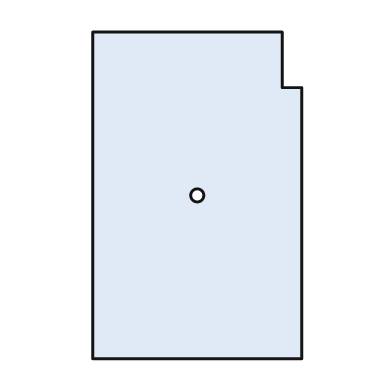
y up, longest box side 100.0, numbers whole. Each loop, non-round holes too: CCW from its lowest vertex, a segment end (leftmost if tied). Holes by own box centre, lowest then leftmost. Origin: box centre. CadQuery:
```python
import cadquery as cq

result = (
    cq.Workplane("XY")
    .moveTo(-32.0, -50.0)
    .lineTo(32.0, -50.0)
    .lineTo(32.0, 33.0)
    .lineTo(26.0, 33.0)
    .lineTo(26.0, 50.0)
    .lineTo(-32.0, 50.0)
    .close()
    .moveTo(0.0, 0.0)
    .circle(2.0)
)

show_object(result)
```